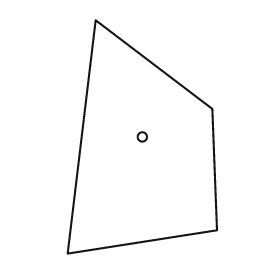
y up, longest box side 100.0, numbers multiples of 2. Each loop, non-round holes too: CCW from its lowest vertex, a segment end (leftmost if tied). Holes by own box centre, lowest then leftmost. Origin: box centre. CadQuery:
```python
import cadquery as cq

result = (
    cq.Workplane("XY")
    .moveTo(-32.0, -50.0)
    .lineTo(32.0, -40.0)
    .lineTo(30.0, 12.0)
    .lineTo(-20.0, 50.0)
    .close()
    .moveTo(0.0, 0.0)
    .circle(2.0)
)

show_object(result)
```